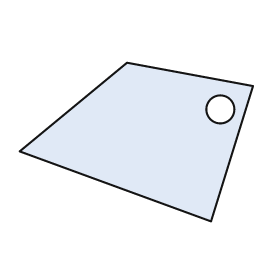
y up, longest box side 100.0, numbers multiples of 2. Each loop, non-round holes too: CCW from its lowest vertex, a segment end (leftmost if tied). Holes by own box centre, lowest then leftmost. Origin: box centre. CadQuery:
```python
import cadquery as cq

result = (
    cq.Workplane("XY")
    .moveTo(32.0, -34.0)
    .lineTo(50.0, 24.0)
    .lineTo(-4.0, 34.0)
    .lineTo(-50.0, -4.0)
    .close()
    .moveTo(36.0, 14.0)
    .circle(6.0)
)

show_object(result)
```